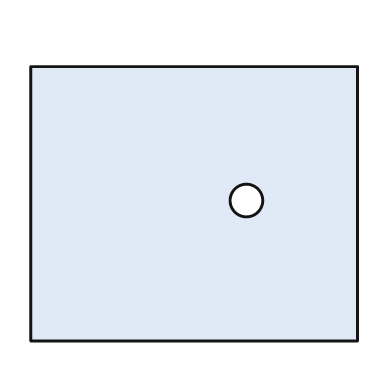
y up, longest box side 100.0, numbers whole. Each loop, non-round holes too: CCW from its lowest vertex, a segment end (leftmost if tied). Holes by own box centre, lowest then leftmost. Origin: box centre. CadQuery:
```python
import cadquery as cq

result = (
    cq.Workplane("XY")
    .moveTo(-50.0, -42.0)
    .lineTo(50.0, -42.0)
    .lineTo(50.0, 42.0)
    .lineTo(-50.0, 42.0)
    .close()
    .moveTo(16.0, 1.0)
    .circle(5.0)
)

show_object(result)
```